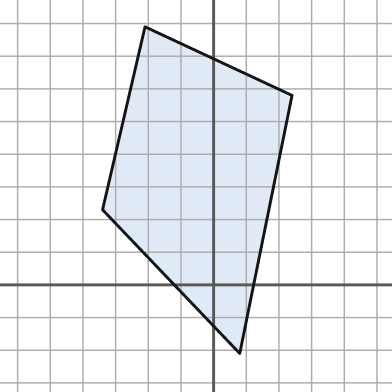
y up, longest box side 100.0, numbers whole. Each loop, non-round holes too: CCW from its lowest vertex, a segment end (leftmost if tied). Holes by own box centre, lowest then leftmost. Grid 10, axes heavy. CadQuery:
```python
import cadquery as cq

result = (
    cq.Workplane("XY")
    .moveTo(8.0, -21.0)
    .lineTo(24.0, 58.0)
    .lineTo(-21.0, 79.0)
    .lineTo(-34.0, 23.0)
    .close()
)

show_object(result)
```